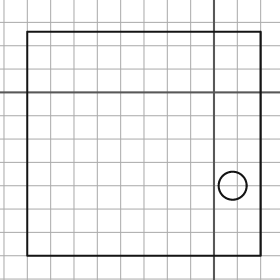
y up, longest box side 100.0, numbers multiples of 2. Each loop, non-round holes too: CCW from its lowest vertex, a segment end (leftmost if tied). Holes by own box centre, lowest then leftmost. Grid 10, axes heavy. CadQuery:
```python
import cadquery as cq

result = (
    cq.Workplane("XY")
    .moveTo(-80.0, -70.0)
    .lineTo(20.0, -70.0)
    .lineTo(20.0, 26.0)
    .lineTo(-80.0, 26.0)
    .close()
    .moveTo(8.0, -40.0)
    .circle(6.0)
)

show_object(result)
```